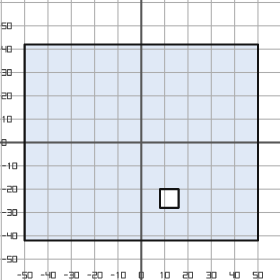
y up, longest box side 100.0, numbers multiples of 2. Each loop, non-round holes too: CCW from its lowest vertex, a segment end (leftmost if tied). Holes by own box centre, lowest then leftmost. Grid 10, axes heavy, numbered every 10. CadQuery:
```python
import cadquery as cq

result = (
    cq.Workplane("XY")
    .moveTo(-50.0, -42.0)
    .lineTo(50.0, -42.0)
    .lineTo(50.0, 42.0)
    .lineTo(-50.0, 42.0)
    .close()
    .moveTo(8.0, -28.0)
    .lineTo(16.0, -28.0)
    .lineTo(16.0, -20.0)
    .lineTo(8.0, -20.0)
    .close()
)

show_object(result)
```